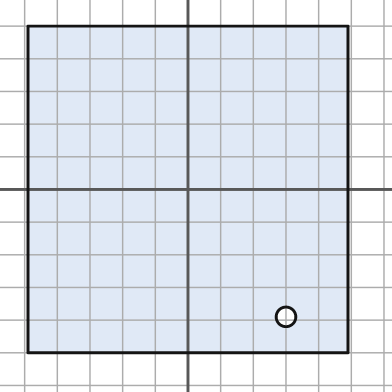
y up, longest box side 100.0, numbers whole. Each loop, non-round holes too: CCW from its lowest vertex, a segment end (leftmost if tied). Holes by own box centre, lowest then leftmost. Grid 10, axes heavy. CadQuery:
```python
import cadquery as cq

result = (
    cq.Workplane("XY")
    .moveTo(-49.0, -50.0)
    .lineTo(49.0, -50.0)
    .lineTo(49.0, 50.0)
    .lineTo(-49.0, 50.0)
    .close()
    .moveTo(30.0, -39.0)
    .circle(3.0)
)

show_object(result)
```